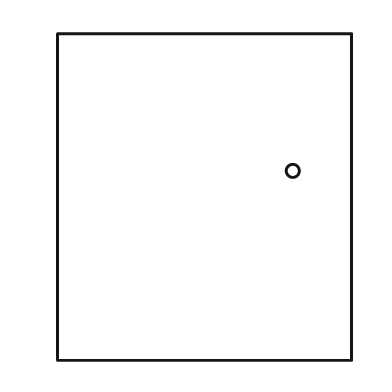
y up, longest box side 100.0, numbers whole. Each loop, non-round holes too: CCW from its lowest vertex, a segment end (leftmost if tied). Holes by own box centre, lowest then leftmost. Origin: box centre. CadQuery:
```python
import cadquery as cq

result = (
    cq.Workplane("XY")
    .moveTo(-45.0, -50.0)
    .lineTo(45.0, -50.0)
    .lineTo(45.0, 50.0)
    .lineTo(-45.0, 50.0)
    .close()
    .moveTo(27.0, 8.0)
    .circle(2.0)
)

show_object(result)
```